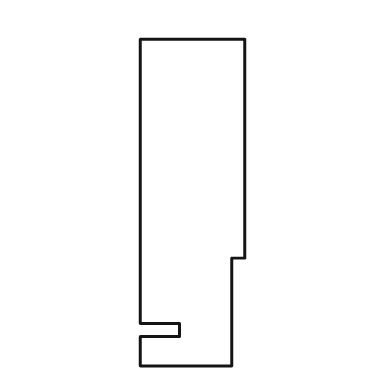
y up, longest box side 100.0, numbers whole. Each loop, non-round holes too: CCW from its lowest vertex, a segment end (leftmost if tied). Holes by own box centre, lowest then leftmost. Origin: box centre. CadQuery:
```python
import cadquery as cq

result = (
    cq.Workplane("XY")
    .moveTo(-16.0, -50.0)
    .lineTo(12.0, -50.0)
    .lineTo(12.0, -17.0)
    .lineTo(16.0, -17.0)
    .lineTo(16.0, 50.0)
    .lineTo(-16.0, 50.0)
    .lineTo(-16.0, -37.0)
    .lineTo(-4.0, -37.0)
    .lineTo(-4.0, -41.0)
    .lineTo(-16.0, -41.0)
    .close()
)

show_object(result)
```